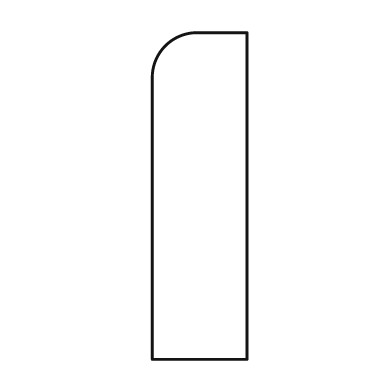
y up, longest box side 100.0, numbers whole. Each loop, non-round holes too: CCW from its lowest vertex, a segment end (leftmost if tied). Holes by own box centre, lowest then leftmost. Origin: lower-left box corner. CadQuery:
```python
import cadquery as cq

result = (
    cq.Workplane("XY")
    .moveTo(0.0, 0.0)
    .lineTo(29.0, 0.0)
    .lineTo(29.0, 100.0)
    .lineTo(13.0, 100.0)
    .threePointArc((4.0, 96.0), (0.0, 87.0))
    .close()
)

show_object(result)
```